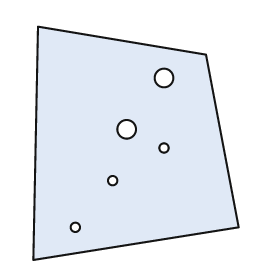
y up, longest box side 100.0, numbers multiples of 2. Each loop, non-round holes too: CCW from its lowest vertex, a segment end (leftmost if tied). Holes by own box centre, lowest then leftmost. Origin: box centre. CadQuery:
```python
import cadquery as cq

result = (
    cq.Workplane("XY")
    .moveTo(-44.0, -50.0)
    .lineTo(44.0, -36.0)
    .lineTo(30.0, 38.0)
    .lineTo(-42.0, 50.0)
    .close()
    .moveTo(-26.0, -36.0)
    .circle(2.0)
    .moveTo(-10.0, -16.0)
    .circle(2.0)
    .moveTo(12.0, -2.0)
    .circle(2.0)
    .moveTo(-4.0, 6.0)
    .circle(4.0)
    .moveTo(12.0, 28.0)
    .circle(4.0)
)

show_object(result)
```